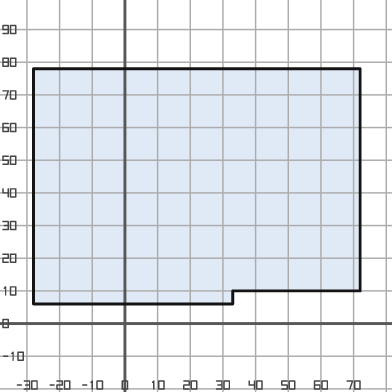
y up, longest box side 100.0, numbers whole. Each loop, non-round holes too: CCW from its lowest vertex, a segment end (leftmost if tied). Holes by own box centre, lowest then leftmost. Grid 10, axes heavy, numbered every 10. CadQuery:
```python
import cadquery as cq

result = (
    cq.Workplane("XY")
    .moveTo(-28.0, 6.0)
    .lineTo(33.0, 6.0)
    .lineTo(33.0, 10.0)
    .lineTo(72.0, 10.0)
    .lineTo(72.0, 78.0)
    .lineTo(-28.0, 78.0)
    .close()
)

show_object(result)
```